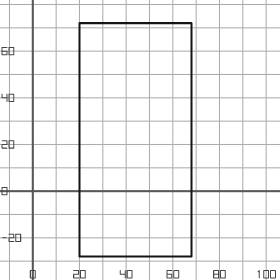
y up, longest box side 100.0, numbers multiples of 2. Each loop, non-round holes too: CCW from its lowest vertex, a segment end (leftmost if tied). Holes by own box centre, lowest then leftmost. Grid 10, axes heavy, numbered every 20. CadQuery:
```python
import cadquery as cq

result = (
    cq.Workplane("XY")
    .moveTo(20.0, -28.0)
    .lineTo(68.0, -28.0)
    .lineTo(68.0, 72.0)
    .lineTo(20.0, 72.0)
    .close()
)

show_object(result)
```